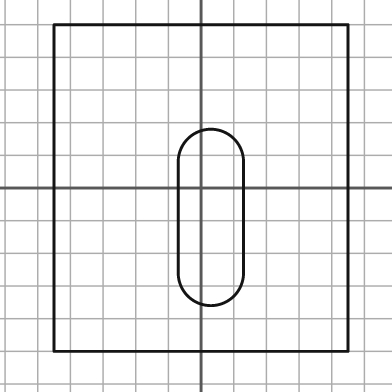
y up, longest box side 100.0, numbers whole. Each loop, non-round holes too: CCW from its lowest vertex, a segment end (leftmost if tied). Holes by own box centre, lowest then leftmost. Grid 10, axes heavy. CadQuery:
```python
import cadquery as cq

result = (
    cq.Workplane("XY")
    .moveTo(-45.0, -50.0)
    .lineTo(45.0, -50.0)
    .lineTo(45.0, 50.0)
    .lineTo(-45.0, 50.0)
    .close()
    .moveTo(-7.0, -26.0)
    .threePointArc((3.0, -36.0), (13.0, -26.0))
    .lineTo(13.0, 8.0)
    .threePointArc((3.0, 18.0), (-7.0, 8.0))
    .close()
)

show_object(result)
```